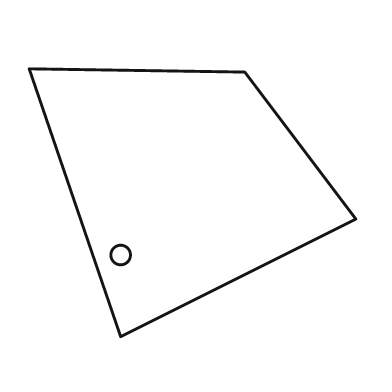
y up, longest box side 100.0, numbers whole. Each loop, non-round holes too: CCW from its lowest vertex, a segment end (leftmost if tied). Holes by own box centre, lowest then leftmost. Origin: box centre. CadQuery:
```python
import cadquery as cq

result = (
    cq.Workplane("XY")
    .moveTo(-22.0, -41.0)
    .lineTo(50.0, -5.0)
    .lineTo(16.0, 40.0)
    .lineTo(-50.0, 41.0)
    .close()
    .moveTo(-22.0, -16.0)
    .circle(3.0)
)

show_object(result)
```